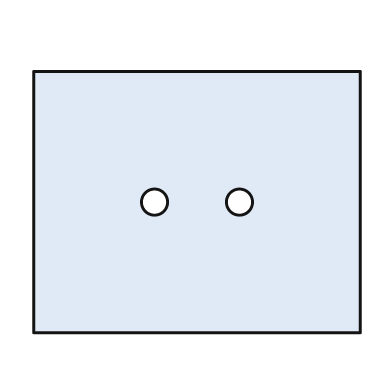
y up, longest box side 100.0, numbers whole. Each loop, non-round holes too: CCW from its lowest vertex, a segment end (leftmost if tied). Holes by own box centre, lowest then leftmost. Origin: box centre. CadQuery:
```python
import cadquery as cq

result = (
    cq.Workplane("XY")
    .moveTo(-50.0, -40.0)
    .lineTo(50.0, -40.0)
    .lineTo(50.0, 40.0)
    .lineTo(-50.0, 40.0)
    .close()
    .moveTo(-13.0, 0.0)
    .circle(4.0)
    .moveTo(13.0, 0.0)
    .circle(4.0)
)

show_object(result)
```